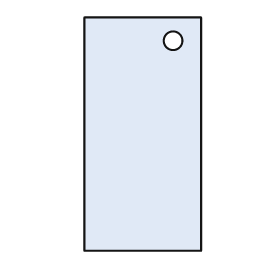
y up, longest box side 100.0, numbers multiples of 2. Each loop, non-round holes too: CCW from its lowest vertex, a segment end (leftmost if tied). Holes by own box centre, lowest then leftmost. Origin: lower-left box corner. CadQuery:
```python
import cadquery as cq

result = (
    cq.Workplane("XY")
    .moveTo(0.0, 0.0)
    .lineTo(50.0, 0.0)
    .lineTo(50.0, 100.0)
    .lineTo(0.0, 100.0)
    .close()
    .moveTo(38.0, 90.0)
    .circle(4.0)
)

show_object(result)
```